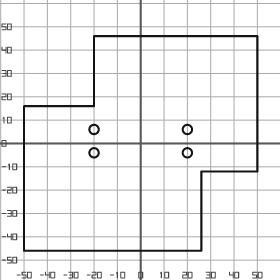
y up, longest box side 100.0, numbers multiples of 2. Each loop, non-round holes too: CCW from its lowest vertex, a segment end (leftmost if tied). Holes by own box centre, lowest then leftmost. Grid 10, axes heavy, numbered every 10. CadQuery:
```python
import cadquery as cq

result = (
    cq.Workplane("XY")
    .moveTo(-50.0, -46.0)
    .lineTo(26.0, -46.0)
    .lineTo(26.0, -12.0)
    .lineTo(50.0, -12.0)
    .lineTo(50.0, 46.0)
    .lineTo(-20.0, 46.0)
    .lineTo(-20.0, 16.0)
    .lineTo(-50.0, 16.0)
    .close()
    .moveTo(-20.0, -4.0)
    .circle(2.0)
    .moveTo(20.0, -4.0)
    .circle(2.0)
    .moveTo(-20.0, 6.0)
    .circle(2.0)
    .moveTo(20.0, 6.0)
    .circle(2.0)
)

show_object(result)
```